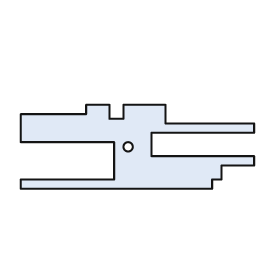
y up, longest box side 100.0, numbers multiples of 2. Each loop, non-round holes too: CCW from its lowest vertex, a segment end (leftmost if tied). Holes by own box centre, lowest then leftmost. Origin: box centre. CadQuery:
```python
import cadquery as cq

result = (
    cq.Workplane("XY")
    .moveTo(-50.0, -18.0)
    .lineTo(32.0, -18.0)
    .lineTo(32.0, -14.0)
    .lineTo(36.0, -14.0)
    .lineTo(36.0, -8.0)
    .lineTo(50.0, -8.0)
    .lineTo(50.0, -4.0)
    .lineTo(6.0, -4.0)
    .lineTo(6.0, 6.0)
    .lineTo(50.0, 6.0)
    .lineTo(50.0, 10.0)
    .lineTo(12.0, 10.0)
    .lineTo(12.0, 18.0)
    .lineTo(-6.0, 18.0)
    .lineTo(-6.0, 12.0)
    .lineTo(-12.0, 12.0)
    .lineTo(-12.0, 18.0)
    .lineTo(-22.0, 18.0)
    .lineTo(-22.0, 14.0)
    .lineTo(-50.0, 14.0)
    .lineTo(-50.0, 2.0)
    .lineTo(-10.0, 2.0)
    .lineTo(-10.0, -14.0)
    .lineTo(-50.0, -14.0)
    .close()
    .moveTo(-4.0, 0.0)
    .circle(2.0)
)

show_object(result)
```